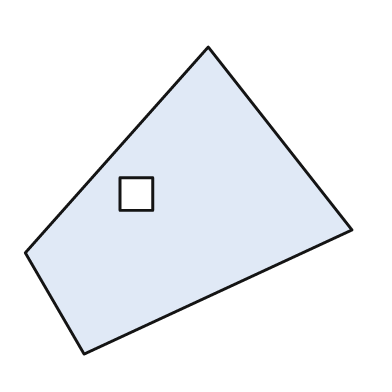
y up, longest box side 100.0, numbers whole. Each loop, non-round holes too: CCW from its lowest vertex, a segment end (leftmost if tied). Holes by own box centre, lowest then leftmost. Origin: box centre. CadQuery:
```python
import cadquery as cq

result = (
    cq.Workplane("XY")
    .moveTo(-32.0, -47.0)
    .lineTo(50.0, -9.0)
    .lineTo(6.0, 47.0)
    .lineTo(-50.0, -16.0)
    .close()
    .moveTo(-21.0, -3.0)
    .lineTo(-11.0, -3.0)
    .lineTo(-11.0, 7.0)
    .lineTo(-21.0, 7.0)
    .close()
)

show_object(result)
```